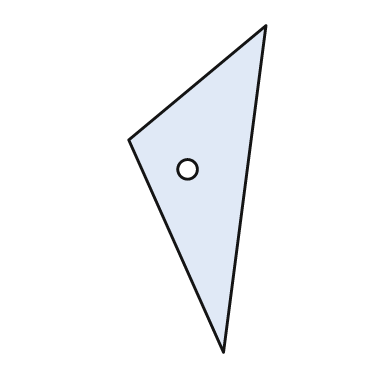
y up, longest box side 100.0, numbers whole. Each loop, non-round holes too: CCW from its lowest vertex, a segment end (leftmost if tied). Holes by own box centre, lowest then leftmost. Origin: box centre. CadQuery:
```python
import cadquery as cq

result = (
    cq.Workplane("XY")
    .moveTo(8.0, -50.0)
    .lineTo(21.0, 50.0)
    .lineTo(-21.0, 15.0)
    .close()
    .moveTo(-3.0, 6.0)
    .circle(3.0)
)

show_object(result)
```